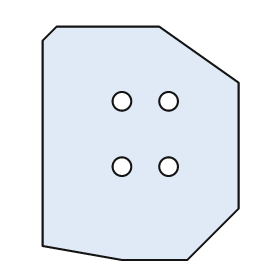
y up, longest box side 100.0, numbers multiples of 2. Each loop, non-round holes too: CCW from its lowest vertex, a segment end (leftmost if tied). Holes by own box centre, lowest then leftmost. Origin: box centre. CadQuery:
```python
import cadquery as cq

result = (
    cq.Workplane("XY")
    .moveTo(-8.0, -50.0)
    .lineTo(20.0, -50.0)
    .lineTo(42.0, -28.0)
    .lineTo(42.0, 26.0)
    .lineTo(8.0, 50.0)
    .lineTo(-36.0, 50.0)
    .lineTo(-42.0, 44.0)
    .lineTo(-42.0, -44.0)
    .close()
    .moveTo(-8.0, -10.0)
    .circle(4.0)
    .moveTo(12.0, -10.0)
    .circle(4.0)
    .moveTo(-8.0, 18.0)
    .circle(4.0)
    .moveTo(12.0, 18.0)
    .circle(4.0)
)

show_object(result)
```